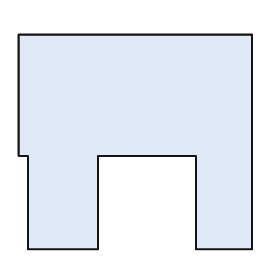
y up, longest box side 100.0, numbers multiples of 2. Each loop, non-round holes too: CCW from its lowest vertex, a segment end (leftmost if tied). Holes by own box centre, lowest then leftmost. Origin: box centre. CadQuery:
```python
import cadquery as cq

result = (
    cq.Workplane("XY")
    .moveTo(-46.0, -46.0)
    .lineTo(-16.0, -46.0)
    .lineTo(-16.0, -6.0)
    .lineTo(26.0, -6.0)
    .lineTo(26.0, -46.0)
    .lineTo(50.0, -46.0)
    .lineTo(50.0, 46.0)
    .lineTo(-50.0, 46.0)
    .lineTo(-50.0, -6.0)
    .lineTo(-46.0, -6.0)
    .close()
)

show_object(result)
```